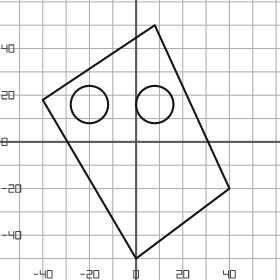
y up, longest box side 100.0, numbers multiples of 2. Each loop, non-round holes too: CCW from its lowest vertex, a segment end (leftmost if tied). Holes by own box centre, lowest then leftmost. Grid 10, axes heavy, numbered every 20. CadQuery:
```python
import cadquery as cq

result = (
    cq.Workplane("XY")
    .moveTo(0.0, -50.0)
    .lineTo(40.0, -20.0)
    .lineTo(8.0, 50.0)
    .lineTo(-40.0, 18.0)
    .close()
    .moveTo(-20.0, 16.0)
    .circle(8.0)
    .moveTo(8.0, 16.0)
    .circle(8.0)
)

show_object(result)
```